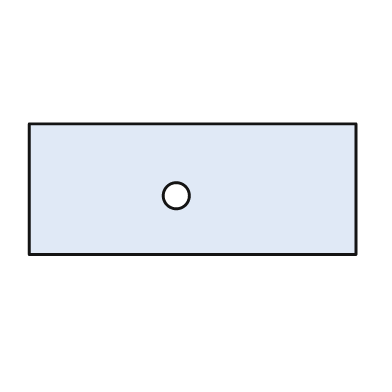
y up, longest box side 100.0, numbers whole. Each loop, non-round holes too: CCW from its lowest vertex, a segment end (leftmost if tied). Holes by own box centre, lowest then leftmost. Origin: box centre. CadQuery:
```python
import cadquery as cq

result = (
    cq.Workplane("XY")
    .moveTo(-50.0, -20.0)
    .lineTo(50.0, -20.0)
    .lineTo(50.0, 20.0)
    .lineTo(-50.0, 20.0)
    .close()
    .moveTo(-5.0, -2.0)
    .circle(4.0)
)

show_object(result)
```